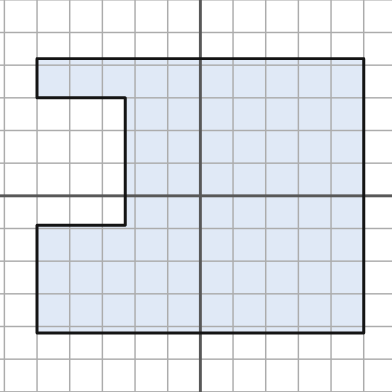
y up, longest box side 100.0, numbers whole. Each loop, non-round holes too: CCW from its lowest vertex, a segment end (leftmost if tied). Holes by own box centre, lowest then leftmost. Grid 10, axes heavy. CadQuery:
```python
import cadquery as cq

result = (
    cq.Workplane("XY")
    .moveTo(-50.0, -42.0)
    .lineTo(50.0, -42.0)
    .lineTo(50.0, 42.0)
    .lineTo(-50.0, 42.0)
    .lineTo(-50.0, 30.0)
    .lineTo(-23.0, 30.0)
    .lineTo(-23.0, -9.0)
    .lineTo(-50.0, -9.0)
    .close()
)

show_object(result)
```